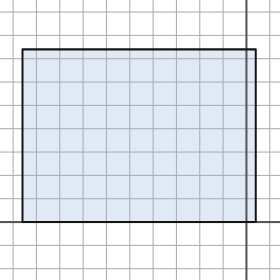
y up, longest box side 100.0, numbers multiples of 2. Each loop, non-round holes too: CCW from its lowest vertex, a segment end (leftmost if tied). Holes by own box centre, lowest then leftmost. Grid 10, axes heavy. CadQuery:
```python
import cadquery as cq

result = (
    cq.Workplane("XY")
    .moveTo(-96.0, 0.0)
    .lineTo(4.0, 0.0)
    .lineTo(4.0, 74.0)
    .lineTo(-96.0, 74.0)
    .close()
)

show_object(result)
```